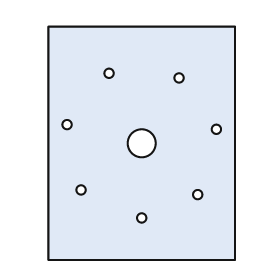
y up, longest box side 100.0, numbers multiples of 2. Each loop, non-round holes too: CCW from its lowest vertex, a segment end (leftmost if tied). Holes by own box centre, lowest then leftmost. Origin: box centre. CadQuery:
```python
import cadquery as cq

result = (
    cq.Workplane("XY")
    .moveTo(-40.0, -50.0)
    .lineTo(40.0, -50.0)
    .lineTo(40.0, 50.0)
    .lineTo(-40.0, 50.0)
    .close()
    .moveTo(0.0, -32.0)
    .circle(2.0)
    .moveTo(24.0, -22.0)
    .circle(2.0)
    .moveTo(-26.0, -20.0)
    .circle(2.0)
    .moveTo(0.0, 0.0)
    .circle(6.0)
    .moveTo(32.0, 6.0)
    .circle(2.0)
    .moveTo(-32.0, 8.0)
    .circle(2.0)
    .moveTo(16.0, 28.0)
    .circle(2.0)
    .moveTo(-14.0, 30.0)
    .circle(2.0)
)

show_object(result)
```